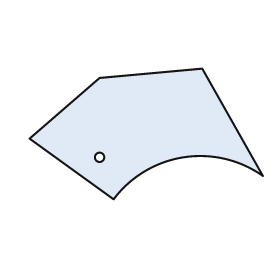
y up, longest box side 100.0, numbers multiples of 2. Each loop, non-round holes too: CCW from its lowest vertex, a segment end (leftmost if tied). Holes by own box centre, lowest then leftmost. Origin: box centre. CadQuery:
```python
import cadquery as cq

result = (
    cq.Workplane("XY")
    .moveTo(-14.0, -28.0)
    .threePointArc((16.0, -10.0), (50.0, -18.0))
    .lineTo(24.0, 28.0)
    .lineTo(-20.0, 24.0)
    .lineTo(-50.0, -2.0)
    .close()
    .moveTo(-20.0, -10.0)
    .circle(2.0)
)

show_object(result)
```